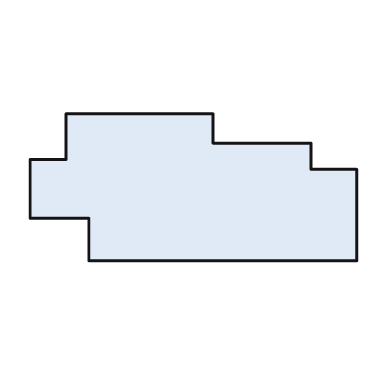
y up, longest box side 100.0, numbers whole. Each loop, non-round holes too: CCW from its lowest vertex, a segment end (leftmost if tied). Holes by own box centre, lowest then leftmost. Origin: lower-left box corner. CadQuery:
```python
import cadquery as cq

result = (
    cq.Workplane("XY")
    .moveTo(18.0, 0.0)
    .lineTo(100.0, 0.0)
    .lineTo(100.0, 28.0)
    .lineTo(86.0, 28.0)
    .lineTo(86.0, 36.0)
    .lineTo(56.0, 36.0)
    .lineTo(56.0, 45.0)
    .lineTo(11.0, 45.0)
    .lineTo(11.0, 31.0)
    .lineTo(0.0, 31.0)
    .lineTo(0.0, 13.0)
    .lineTo(18.0, 13.0)
    .close()
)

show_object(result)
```